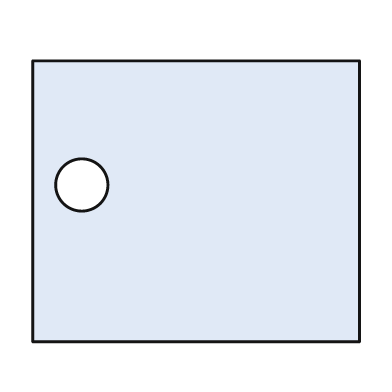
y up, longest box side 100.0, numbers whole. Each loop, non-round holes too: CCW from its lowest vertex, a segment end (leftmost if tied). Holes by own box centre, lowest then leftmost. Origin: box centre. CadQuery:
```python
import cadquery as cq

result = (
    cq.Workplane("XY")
    .moveTo(-50.0, -43.0)
    .lineTo(50.0, -43.0)
    .lineTo(50.0, 43.0)
    .lineTo(-50.0, 43.0)
    .close()
    .moveTo(-35.0, 5.0)
    .circle(8.0)
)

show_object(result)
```